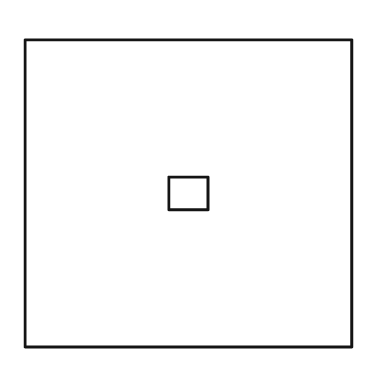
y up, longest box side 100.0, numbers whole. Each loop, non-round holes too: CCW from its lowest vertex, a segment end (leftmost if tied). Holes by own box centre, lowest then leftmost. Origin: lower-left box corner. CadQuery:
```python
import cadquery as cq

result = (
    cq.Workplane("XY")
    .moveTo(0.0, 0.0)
    .lineTo(100.0, 0.0)
    .lineTo(100.0, 94.0)
    .lineTo(0.0, 94.0)
    .close()
    .moveTo(44.0, 42.0)
    .lineTo(56.0, 42.0)
    .lineTo(56.0, 52.0)
    .lineTo(44.0, 52.0)
    .close()
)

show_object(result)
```